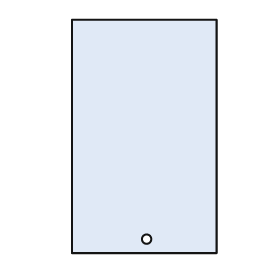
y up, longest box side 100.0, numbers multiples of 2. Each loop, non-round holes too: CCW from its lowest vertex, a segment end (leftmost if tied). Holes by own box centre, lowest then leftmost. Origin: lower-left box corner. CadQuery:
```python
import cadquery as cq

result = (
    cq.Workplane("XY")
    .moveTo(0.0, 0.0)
    .lineTo(62.0, 0.0)
    .lineTo(62.0, 100.0)
    .lineTo(0.0, 100.0)
    .close()
    .moveTo(32.0, 6.0)
    .circle(2.0)
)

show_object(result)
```